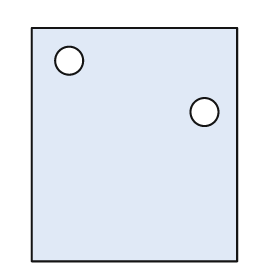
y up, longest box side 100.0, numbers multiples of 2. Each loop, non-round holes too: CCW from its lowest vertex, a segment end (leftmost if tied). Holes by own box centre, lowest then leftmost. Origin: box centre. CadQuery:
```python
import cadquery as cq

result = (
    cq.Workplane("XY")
    .moveTo(-44.0, -50.0)
    .lineTo(44.0, -50.0)
    .lineTo(44.0, 50.0)
    .lineTo(-44.0, 50.0)
    .close()
    .moveTo(30.0, 14.0)
    .circle(6.0)
    .moveTo(-28.0, 36.0)
    .circle(6.0)
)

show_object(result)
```